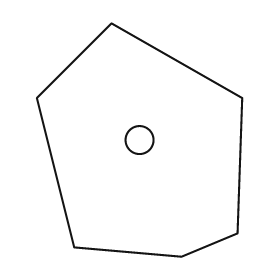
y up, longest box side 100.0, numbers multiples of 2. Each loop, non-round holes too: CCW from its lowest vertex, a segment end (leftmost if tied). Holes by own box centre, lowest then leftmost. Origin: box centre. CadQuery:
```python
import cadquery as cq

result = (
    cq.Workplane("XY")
    .moveTo(18.0, -50.0)
    .lineTo(42.0, -40.0)
    .lineTo(44.0, 18.0)
    .lineTo(-12.0, 50.0)
    .lineTo(-44.0, 18.0)
    .lineTo(-28.0, -46.0)
    .close()
    .moveTo(0.0, 0.0)
    .circle(6.0)
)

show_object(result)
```